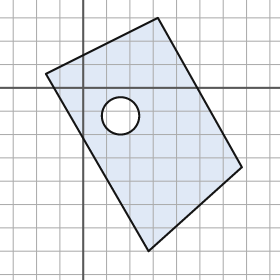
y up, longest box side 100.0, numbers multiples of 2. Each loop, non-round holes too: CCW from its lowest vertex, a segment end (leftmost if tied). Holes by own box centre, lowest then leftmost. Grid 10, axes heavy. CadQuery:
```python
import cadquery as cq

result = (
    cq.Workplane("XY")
    .moveTo(28.0, -70.0)
    .lineTo(68.0, -34.0)
    .lineTo(32.0, 30.0)
    .lineTo(-16.0, 6.0)
    .close()
    .moveTo(16.0, -12.0)
    .circle(8.0)
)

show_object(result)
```